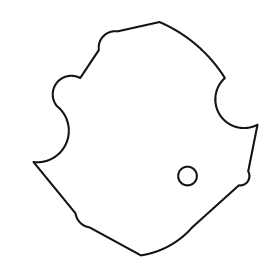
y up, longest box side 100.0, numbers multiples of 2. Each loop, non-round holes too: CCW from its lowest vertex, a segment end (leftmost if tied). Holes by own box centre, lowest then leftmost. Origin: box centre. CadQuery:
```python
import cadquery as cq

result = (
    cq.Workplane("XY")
    .moveTo(-2.0, -50.0)
    .threePointArc((10.0, -46.0), (20.0, -38.0))
    .lineTo(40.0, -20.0)
    .threePointArc((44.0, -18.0), (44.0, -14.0))
    .lineTo(48.0, 6.0)
    .threePointArc((32.0, 10.0), (34.0, 26.0))
    .threePointArc((22.0, 40.0), (6.0, 50.0))
    .lineTo(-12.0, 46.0)
    .threePointArc((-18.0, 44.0), (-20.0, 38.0))
    .lineTo(-28.0, 26.0)
    .threePointArc((-38.0, 24.0), (-38.0, 14.0))
    .threePointArc((-34.0, -2.0), (-48.0, -10.0))
    .lineTo(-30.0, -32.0)
    .threePointArc((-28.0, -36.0), (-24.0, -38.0))
    .close()
    .moveTo(18.0, -16.0)
    .circle(4.0)
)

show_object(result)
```